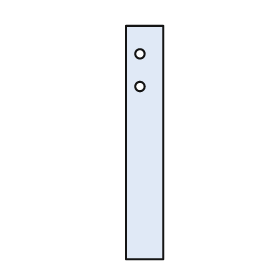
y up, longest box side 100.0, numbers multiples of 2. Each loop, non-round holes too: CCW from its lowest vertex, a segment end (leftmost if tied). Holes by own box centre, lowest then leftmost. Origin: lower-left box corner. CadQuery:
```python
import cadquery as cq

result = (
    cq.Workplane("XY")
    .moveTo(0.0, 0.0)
    .lineTo(16.0, 0.0)
    .lineTo(16.0, 100.0)
    .lineTo(0.0, 100.0)
    .close()
    .moveTo(6.0, 74.0)
    .circle(2.0)
    .moveTo(6.0, 88.0)
    .circle(2.0)
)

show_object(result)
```